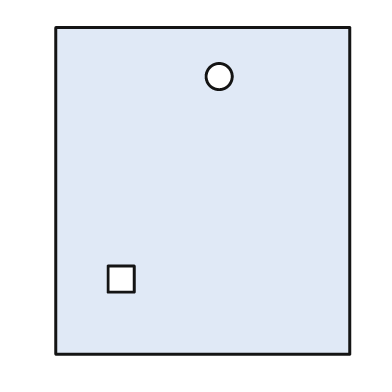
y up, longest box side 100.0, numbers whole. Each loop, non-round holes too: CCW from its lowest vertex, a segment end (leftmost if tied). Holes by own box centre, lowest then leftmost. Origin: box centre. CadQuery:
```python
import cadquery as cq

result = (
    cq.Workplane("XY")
    .moveTo(-45.0, -50.0)
    .lineTo(45.0, -50.0)
    .lineTo(45.0, 50.0)
    .lineTo(-45.0, 50.0)
    .close()
    .moveTo(-29.0, -31.0)
    .lineTo(-21.0, -31.0)
    .lineTo(-21.0, -23.0)
    .lineTo(-29.0, -23.0)
    .close()
    .moveTo(5.0, 35.0)
    .circle(4.0)
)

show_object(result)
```